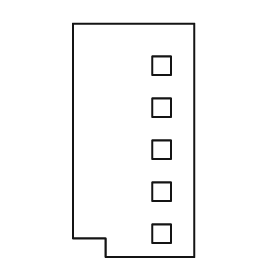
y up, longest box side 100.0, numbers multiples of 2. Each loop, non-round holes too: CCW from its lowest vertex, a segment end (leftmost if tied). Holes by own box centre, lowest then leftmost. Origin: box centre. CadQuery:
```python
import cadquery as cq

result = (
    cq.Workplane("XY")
    .moveTo(-12.0, -50.0)
    .lineTo(26.0, -50.0)
    .lineTo(26.0, 50.0)
    .lineTo(-26.0, 50.0)
    .lineTo(-26.0, -42.0)
    .lineTo(-12.0, -42.0)
    .close()
    .moveTo(8.0, -44.0)
    .lineTo(16.0, -44.0)
    .lineTo(16.0, -36.0)
    .lineTo(8.0, -36.0)
    .close()
    .moveTo(8.0, -26.0)
    .lineTo(16.0, -26.0)
    .lineTo(16.0, -18.0)
    .lineTo(8.0, -18.0)
    .close()
    .moveTo(8.0, -8.0)
    .lineTo(16.0, -8.0)
    .lineTo(16.0, 0.0)
    .lineTo(8.0, 0.0)
    .close()
    .moveTo(8.0, 10.0)
    .lineTo(16.0, 10.0)
    .lineTo(16.0, 18.0)
    .lineTo(8.0, 18.0)
    .close()
    .moveTo(8.0, 28.0)
    .lineTo(16.0, 28.0)
    .lineTo(16.0, 36.0)
    .lineTo(8.0, 36.0)
    .close()
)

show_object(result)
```